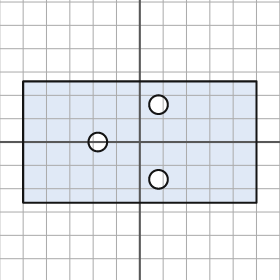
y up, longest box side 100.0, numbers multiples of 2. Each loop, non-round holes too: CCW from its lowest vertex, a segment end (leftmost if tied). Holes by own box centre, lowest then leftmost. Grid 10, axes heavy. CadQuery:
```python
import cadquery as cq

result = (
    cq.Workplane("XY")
    .moveTo(-50.0, -26.0)
    .lineTo(50.0, -26.0)
    .lineTo(50.0, 26.0)
    .lineTo(-50.0, 26.0)
    .close()
    .moveTo(8.0, -16.0)
    .circle(4.0)
    .moveTo(-18.0, 0.0)
    .circle(4.0)
    .moveTo(8.0, 16.0)
    .circle(4.0)
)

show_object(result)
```